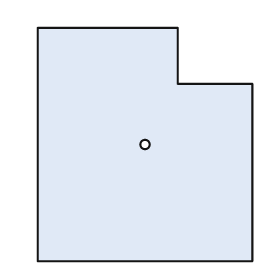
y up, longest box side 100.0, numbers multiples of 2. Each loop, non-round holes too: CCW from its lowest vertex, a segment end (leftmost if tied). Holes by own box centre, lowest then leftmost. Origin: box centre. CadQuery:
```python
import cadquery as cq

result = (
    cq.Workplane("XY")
    .moveTo(-46.0, -50.0)
    .lineTo(46.0, -50.0)
    .lineTo(46.0, 26.0)
    .lineTo(14.0, 26.0)
    .lineTo(14.0, 50.0)
    .lineTo(-46.0, 50.0)
    .close()
    .moveTo(0.0, 0.0)
    .circle(2.0)
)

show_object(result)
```